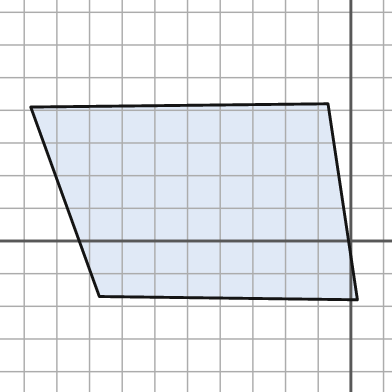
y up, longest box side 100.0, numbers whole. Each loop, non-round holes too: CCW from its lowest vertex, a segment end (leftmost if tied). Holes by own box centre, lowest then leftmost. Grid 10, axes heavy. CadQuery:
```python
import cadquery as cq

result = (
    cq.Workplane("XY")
    .moveTo(2.0, -18.0)
    .lineTo(-7.0, 42.0)
    .lineTo(-98.0, 41.0)
    .lineTo(-77.0, -17.0)
    .close()
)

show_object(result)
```